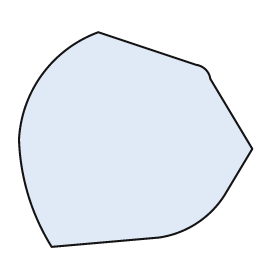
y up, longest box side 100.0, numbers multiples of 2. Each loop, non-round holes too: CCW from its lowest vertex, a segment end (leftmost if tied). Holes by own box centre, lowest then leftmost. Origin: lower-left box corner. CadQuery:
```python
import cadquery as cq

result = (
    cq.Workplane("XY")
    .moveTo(14.0, 0.0)
    .lineTo(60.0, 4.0)
    .threePointArc((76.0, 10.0), (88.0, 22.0))
    .lineTo(100.0, 42.0)
    .lineTo(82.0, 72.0)
    .threePointArc((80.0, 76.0), (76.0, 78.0))
    .lineTo(34.0, 92.0)
    .threePointArc((10.0, 74.0), (0.0, 46.0))
    .threePointArc((4.0, 22.0), (14.0, 0.0))
    .close()
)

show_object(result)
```